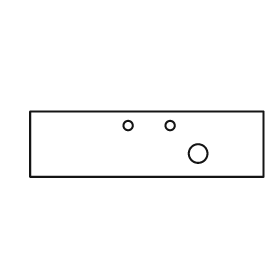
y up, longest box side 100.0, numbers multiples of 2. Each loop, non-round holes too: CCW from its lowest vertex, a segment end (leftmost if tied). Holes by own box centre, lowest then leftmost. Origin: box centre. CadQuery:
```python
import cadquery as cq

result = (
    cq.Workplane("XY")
    .moveTo(-50.0, -14.0)
    .lineTo(50.0, -14.0)
    .lineTo(50.0, 14.0)
    .lineTo(-50.0, 14.0)
    .close()
    .moveTo(22.0, -4.0)
    .circle(4.0)
    .moveTo(-8.0, 8.0)
    .circle(2.0)
    .moveTo(10.0, 8.0)
    .circle(2.0)
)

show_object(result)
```